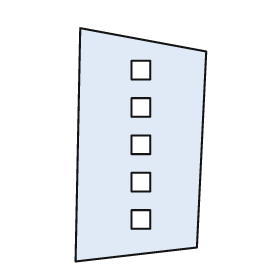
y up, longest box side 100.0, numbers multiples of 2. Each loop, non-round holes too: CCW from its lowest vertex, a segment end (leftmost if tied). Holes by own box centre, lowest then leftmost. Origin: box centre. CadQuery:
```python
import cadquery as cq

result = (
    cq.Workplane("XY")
    .moveTo(-28.0, -50.0)
    .lineTo(24.0, -44.0)
    .lineTo(28.0, 40.0)
    .lineTo(-26.0, 50.0)
    .close()
    .moveTo(-4.0, -36.0)
    .lineTo(4.0, -36.0)
    .lineTo(4.0, -28.0)
    .lineTo(-4.0, -28.0)
    .close()
    .moveTo(-4.0, -20.0)
    .lineTo(4.0, -20.0)
    .lineTo(4.0, -12.0)
    .lineTo(-4.0, -12.0)
    .close()
    .moveTo(-4.0, -4.0)
    .lineTo(4.0, -4.0)
    .lineTo(4.0, 4.0)
    .lineTo(-4.0, 4.0)
    .close()
    .moveTo(-4.0, 12.0)
    .lineTo(4.0, 12.0)
    .lineTo(4.0, 20.0)
    .lineTo(-4.0, 20.0)
    .close()
    .moveTo(-4.0, 28.0)
    .lineTo(4.0, 28.0)
    .lineTo(4.0, 36.0)
    .lineTo(-4.0, 36.0)
    .close()
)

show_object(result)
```